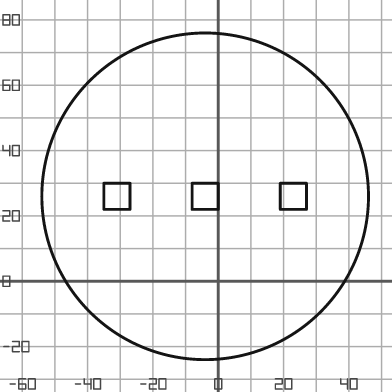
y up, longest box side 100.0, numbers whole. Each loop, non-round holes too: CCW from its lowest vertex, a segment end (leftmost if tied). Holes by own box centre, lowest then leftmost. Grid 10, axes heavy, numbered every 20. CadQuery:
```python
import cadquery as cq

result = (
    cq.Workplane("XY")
    .moveTo(-4.0, 26.0)
    .circle(50.0)
    .moveTo(-35.0, 22.0)
    .lineTo(-27.0, 22.0)
    .lineTo(-27.0, 30.0)
    .lineTo(-35.0, 30.0)
    .close()
    .moveTo(-8.0, 22.0)
    .lineTo(0.0, 22.0)
    .lineTo(0.0, 30.0)
    .lineTo(-8.0, 30.0)
    .close()
    .moveTo(19.0, 22.0)
    .lineTo(27.0, 22.0)
    .lineTo(27.0, 30.0)
    .lineTo(19.0, 30.0)
    .close()
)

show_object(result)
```